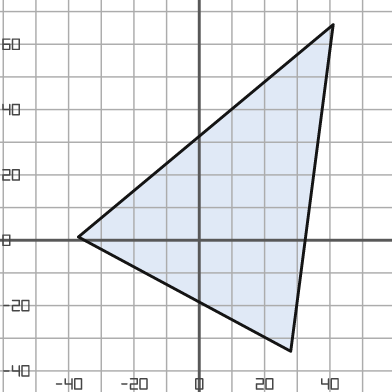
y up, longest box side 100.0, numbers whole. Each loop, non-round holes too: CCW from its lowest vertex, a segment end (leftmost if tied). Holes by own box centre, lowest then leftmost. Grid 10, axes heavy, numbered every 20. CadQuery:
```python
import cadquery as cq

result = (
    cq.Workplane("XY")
    .moveTo(28.0, -34.0)
    .lineTo(41.0, 66.0)
    .lineTo(-37.0, 1.0)
    .close()
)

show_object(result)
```